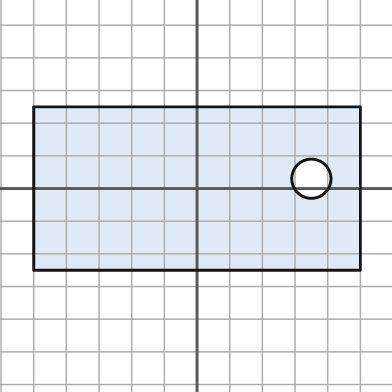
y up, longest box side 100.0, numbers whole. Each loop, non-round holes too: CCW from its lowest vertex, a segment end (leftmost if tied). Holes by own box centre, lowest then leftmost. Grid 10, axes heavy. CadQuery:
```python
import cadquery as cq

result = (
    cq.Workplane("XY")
    .moveTo(-50.0, -25.0)
    .lineTo(50.0, -25.0)
    .lineTo(50.0, 25.0)
    .lineTo(-50.0, 25.0)
    .close()
    .moveTo(35.0, 3.0)
    .circle(6.0)
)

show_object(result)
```